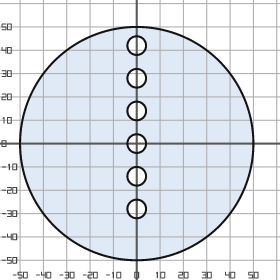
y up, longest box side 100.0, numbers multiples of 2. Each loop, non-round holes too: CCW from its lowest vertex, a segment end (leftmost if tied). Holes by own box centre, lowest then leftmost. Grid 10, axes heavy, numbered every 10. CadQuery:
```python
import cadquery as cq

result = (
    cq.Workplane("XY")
    .moveTo(0.0, 0.0)
    .circle(50.0)
    .moveTo(0.0, -28.0)
    .circle(4.0)
    .moveTo(0.0, -14.0)
    .circle(4.0)
    .moveTo(0.0, 0.0)
    .circle(4.0)
    .moveTo(0.0, 14.0)
    .circle(4.0)
    .moveTo(0.0, 28.0)
    .circle(4.0)
    .moveTo(0.0, 42.0)
    .circle(4.0)
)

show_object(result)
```